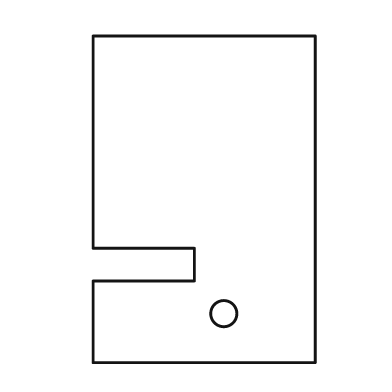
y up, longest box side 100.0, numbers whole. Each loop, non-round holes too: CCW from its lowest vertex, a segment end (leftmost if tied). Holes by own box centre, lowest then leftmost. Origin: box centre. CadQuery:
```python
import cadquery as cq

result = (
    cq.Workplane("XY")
    .moveTo(-34.0, -50.0)
    .lineTo(34.0, -50.0)
    .lineTo(34.0, 50.0)
    .lineTo(-34.0, 50.0)
    .lineTo(-34.0, -15.0)
    .lineTo(-3.0, -15.0)
    .lineTo(-3.0, -25.0)
    .lineTo(-34.0, -25.0)
    .close()
    .moveTo(6.0, -35.0)
    .circle(4.0)
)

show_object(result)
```